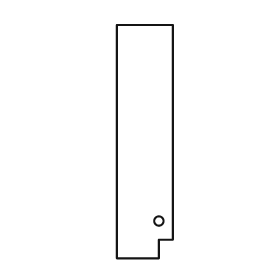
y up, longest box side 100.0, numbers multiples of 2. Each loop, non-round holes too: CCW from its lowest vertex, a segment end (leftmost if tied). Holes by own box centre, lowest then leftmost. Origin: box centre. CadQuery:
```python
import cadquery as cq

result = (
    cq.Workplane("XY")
    .moveTo(-12.0, -50.0)
    .lineTo(6.0, -50.0)
    .lineTo(6.0, -42.0)
    .lineTo(12.0, -42.0)
    .lineTo(12.0, 50.0)
    .lineTo(-12.0, 50.0)
    .close()
    .moveTo(6.0, -34.0)
    .circle(2.0)
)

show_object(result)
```